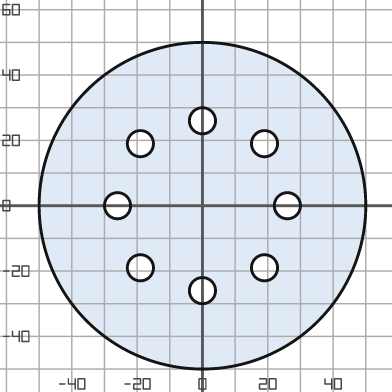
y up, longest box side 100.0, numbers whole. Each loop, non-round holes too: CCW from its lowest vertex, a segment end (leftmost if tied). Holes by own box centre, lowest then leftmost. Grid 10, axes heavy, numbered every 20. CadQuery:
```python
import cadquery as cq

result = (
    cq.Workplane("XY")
    .moveTo(0.0, 0.0)
    .circle(50.0)
    .moveTo(0.0, -26.0)
    .circle(4.0)
    .moveTo(-19.0, -19.0)
    .circle(4.0)
    .moveTo(19.0, -19.0)
    .circle(4.0)
    .moveTo(-26.0, 0.0)
    .circle(4.0)
    .moveTo(26.0, 0.0)
    .circle(4.0)
    .moveTo(-19.0, 19.0)
    .circle(4.0)
    .moveTo(19.0, 19.0)
    .circle(4.0)
    .moveTo(0.0, 26.0)
    .circle(4.0)
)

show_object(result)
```